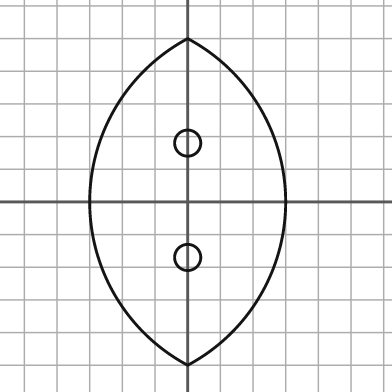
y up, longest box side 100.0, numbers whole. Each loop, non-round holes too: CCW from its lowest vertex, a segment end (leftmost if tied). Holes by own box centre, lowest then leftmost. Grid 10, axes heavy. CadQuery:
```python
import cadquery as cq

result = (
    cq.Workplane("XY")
    .moveTo(0.0, -50.0)
    .threePointArc((30.0, 0.0), (0.0, 50.0))
    .threePointArc((-30.0, 0.0), (0.0, -50.0))
    .close()
    .moveTo(0.0, -17.0)
    .circle(4.0)
    .moveTo(0.0, 18.0)
    .circle(4.0)
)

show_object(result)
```